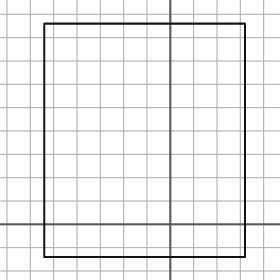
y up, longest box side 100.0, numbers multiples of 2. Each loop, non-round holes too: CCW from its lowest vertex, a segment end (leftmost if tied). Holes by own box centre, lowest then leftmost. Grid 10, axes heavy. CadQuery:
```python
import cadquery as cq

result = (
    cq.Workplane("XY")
    .moveTo(-54.0, -14.0)
    .lineTo(32.0, -14.0)
    .lineTo(32.0, 86.0)
    .lineTo(-54.0, 86.0)
    .close()
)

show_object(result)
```